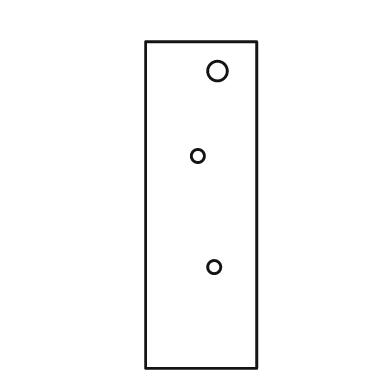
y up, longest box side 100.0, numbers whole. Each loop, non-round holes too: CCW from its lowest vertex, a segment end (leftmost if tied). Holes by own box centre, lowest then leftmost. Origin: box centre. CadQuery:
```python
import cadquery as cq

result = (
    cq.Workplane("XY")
    .moveTo(-17.0, -50.0)
    .lineTo(17.0, -50.0)
    .lineTo(17.0, 50.0)
    .lineTo(-17.0, 50.0)
    .close()
    .moveTo(4.0, -19.0)
    .circle(2.0)
    .moveTo(-1.0, 15.0)
    .circle(2.0)
    .moveTo(5.0, 41.0)
    .circle(3.0)
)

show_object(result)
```